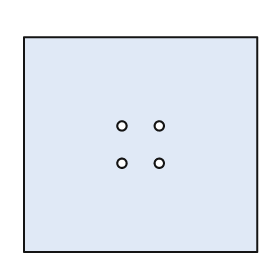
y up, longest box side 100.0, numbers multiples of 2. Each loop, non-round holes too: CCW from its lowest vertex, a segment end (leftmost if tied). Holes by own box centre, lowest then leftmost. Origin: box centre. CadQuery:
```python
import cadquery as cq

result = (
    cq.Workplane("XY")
    .moveTo(-50.0, -46.0)
    .lineTo(50.0, -46.0)
    .lineTo(50.0, 46.0)
    .lineTo(-50.0, 46.0)
    .close()
    .moveTo(-8.0, -8.0)
    .circle(2.0)
    .moveTo(8.0, -8.0)
    .circle(2.0)
    .moveTo(-8.0, 8.0)
    .circle(2.0)
    .moveTo(8.0, 8.0)
    .circle(2.0)
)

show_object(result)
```